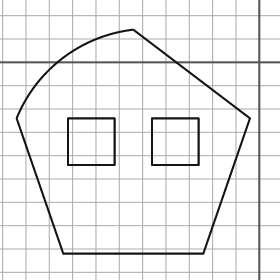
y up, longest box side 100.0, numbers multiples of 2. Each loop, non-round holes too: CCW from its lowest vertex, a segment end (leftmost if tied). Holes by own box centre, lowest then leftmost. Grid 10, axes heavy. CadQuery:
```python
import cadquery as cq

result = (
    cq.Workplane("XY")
    .moveTo(-84.0, -82.0)
    .lineTo(-24.0, -82.0)
    .lineTo(-4.0, -24.0)
    .lineTo(-54.0, 14.0)
    .threePointArc((-84.0, 2.0), (-104.0, -24.0))
    .close()
    .moveTo(-82.0, -44.0)
    .lineTo(-62.0, -44.0)
    .lineTo(-62.0, -24.0)
    .lineTo(-82.0, -24.0)
    .close()
    .moveTo(-46.0, -44.0)
    .lineTo(-26.0, -44.0)
    .lineTo(-26.0, -24.0)
    .lineTo(-46.0, -24.0)
    .close()
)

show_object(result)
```